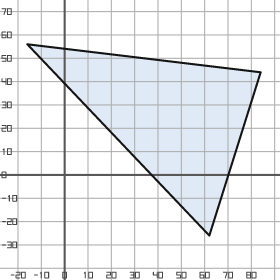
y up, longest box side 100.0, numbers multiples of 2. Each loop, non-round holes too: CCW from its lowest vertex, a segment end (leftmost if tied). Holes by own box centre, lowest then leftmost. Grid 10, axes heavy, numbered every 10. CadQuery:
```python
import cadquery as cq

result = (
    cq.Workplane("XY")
    .moveTo(62.0, -26.0)
    .lineTo(84.0, 44.0)
    .lineTo(-16.0, 56.0)
    .close()
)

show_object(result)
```